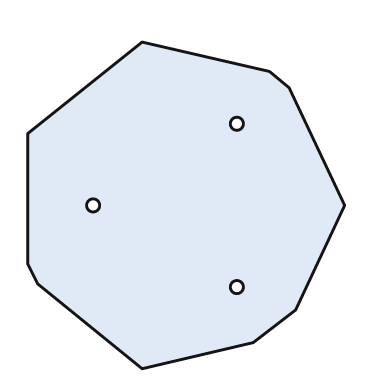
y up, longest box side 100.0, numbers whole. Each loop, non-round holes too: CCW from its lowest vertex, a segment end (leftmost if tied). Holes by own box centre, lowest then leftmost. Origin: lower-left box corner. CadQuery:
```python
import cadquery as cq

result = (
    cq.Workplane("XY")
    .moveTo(35.0, 0.0)
    .lineTo(69.0, 8.0)
    .lineTo(82.0, 18.0)
    .lineTo(97.0, 50.0)
    .lineTo(80.0, 86.0)
    .lineTo(74.0, 91.0)
    .lineTo(35.0, 100.0)
    .lineTo(0.0, 72.0)
    .lineTo(0.0, 32.0)
    .lineTo(3.0, 26.0)
    .close()
    .moveTo(64.0, 25.0)
    .circle(2.0)
    .moveTo(20.0, 50.0)
    .circle(2.0)
    .moveTo(64.0, 75.0)
    .circle(2.0)
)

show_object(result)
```